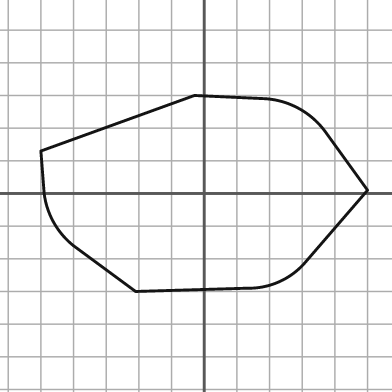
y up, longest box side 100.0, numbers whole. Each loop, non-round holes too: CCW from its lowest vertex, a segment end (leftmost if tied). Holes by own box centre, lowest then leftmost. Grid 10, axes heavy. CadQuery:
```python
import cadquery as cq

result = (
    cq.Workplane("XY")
    .moveTo(-21.0, -30.0)
    .lineTo(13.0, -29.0)
    .threePointArc((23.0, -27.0), (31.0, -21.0))
    .lineTo(50.0, 1.0)
    .lineTo(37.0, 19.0)
    .threePointArc((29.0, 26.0), (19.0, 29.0))
    .lineTo(-3.0, 30.0)
    .lineTo(-50.0, 13.0)
    .lineTo(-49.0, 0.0)
    .threePointArc((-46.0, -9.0), (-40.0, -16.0))
    .close()
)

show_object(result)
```